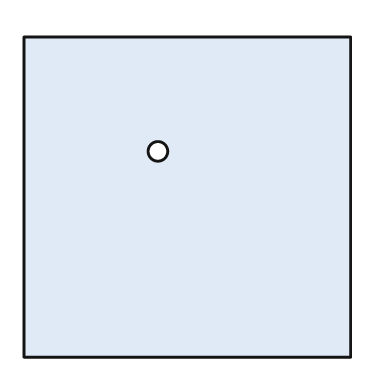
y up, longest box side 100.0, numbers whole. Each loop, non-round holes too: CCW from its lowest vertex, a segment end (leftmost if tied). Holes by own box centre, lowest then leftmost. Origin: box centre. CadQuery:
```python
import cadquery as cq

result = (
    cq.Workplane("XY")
    .moveTo(-50.0, -49.0)
    .lineTo(50.0, -49.0)
    .lineTo(50.0, 49.0)
    .lineTo(-50.0, 49.0)
    .close()
    .moveTo(-9.0, 14.0)
    .circle(3.0)
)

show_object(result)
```